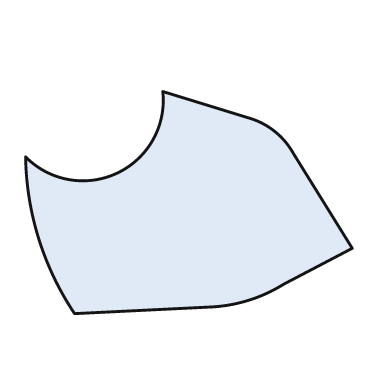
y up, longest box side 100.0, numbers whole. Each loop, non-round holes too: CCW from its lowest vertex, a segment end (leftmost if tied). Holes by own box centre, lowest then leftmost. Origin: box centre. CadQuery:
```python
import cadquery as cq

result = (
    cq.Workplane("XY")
    .moveTo(-35.0, -34.0)
    .lineTo(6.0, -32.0)
    .threePointArc((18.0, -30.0), (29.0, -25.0))
    .lineTo(50.0, -14.0)
    .lineTo(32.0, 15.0)
    .threePointArc((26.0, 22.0), (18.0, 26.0))
    .lineTo(-8.0, 34.0)
    .threePointArc((-22.0, 9.0), (-50.0, 14.0))
    .threePointArc((-46.0, -11.0), (-35.0, -34.0))
    .close()
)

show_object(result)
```